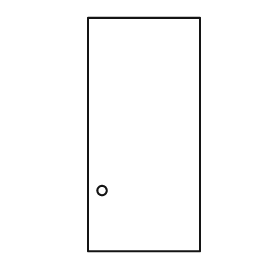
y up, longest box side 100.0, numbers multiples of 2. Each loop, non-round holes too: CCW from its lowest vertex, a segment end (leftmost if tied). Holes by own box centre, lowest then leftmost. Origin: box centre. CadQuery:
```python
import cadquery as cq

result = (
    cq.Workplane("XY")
    .moveTo(-24.0, -50.0)
    .lineTo(24.0, -50.0)
    .lineTo(24.0, 50.0)
    .lineTo(-24.0, 50.0)
    .close()
    .moveTo(-18.0, -24.0)
    .circle(2.0)
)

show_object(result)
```